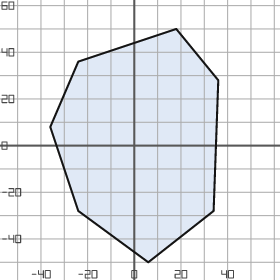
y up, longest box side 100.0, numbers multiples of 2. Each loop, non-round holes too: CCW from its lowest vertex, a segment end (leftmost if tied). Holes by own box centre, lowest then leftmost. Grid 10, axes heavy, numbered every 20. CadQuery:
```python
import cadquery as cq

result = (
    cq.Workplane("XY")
    .moveTo(6.0, -50.0)
    .lineTo(34.0, -28.0)
    .lineTo(36.0, 28.0)
    .lineTo(18.0, 50.0)
    .lineTo(-24.0, 36.0)
    .lineTo(-36.0, 8.0)
    .lineTo(-24.0, -28.0)
    .close()
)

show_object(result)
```